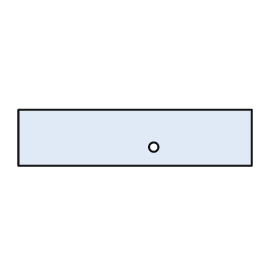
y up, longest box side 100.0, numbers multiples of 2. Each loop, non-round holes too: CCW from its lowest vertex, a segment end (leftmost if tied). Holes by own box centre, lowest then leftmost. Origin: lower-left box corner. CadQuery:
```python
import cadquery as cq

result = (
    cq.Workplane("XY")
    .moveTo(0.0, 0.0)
    .lineTo(100.0, 0.0)
    .lineTo(100.0, 24.0)
    .lineTo(0.0, 24.0)
    .close()
    .moveTo(58.0, 8.0)
    .circle(2.0)
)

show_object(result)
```